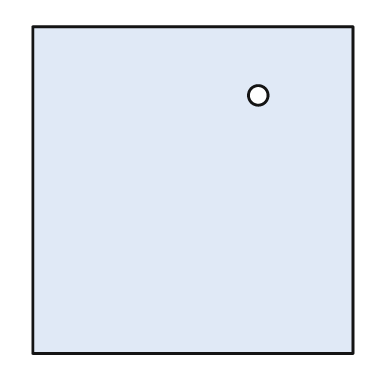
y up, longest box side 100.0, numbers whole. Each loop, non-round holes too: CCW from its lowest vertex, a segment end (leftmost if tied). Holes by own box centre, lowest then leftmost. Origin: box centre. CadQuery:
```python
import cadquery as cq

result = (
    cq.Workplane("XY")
    .moveTo(-49.0, -50.0)
    .lineTo(49.0, -50.0)
    .lineTo(49.0, 50.0)
    .lineTo(-49.0, 50.0)
    .close()
    .moveTo(20.0, 29.0)
    .circle(3.0)
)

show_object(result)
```